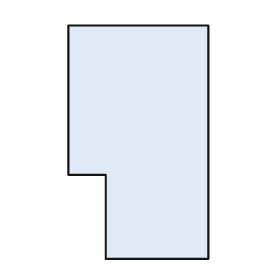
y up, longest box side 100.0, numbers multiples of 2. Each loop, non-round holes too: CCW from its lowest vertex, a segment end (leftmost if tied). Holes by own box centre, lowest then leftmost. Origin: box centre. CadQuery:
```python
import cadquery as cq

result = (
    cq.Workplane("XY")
    .moveTo(-14.0, -50.0)
    .lineTo(30.0, -50.0)
    .lineTo(30.0, 50.0)
    .lineTo(-30.0, 50.0)
    .lineTo(-30.0, -14.0)
    .lineTo(-14.0, -14.0)
    .close()
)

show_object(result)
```